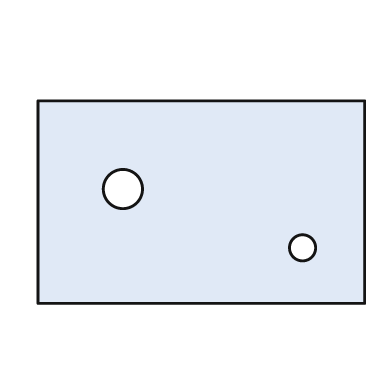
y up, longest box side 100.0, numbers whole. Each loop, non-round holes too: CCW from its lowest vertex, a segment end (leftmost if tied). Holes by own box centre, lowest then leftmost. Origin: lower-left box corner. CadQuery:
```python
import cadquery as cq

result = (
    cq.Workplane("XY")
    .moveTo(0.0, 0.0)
    .lineTo(100.0, 0.0)
    .lineTo(100.0, 62.0)
    .lineTo(0.0, 62.0)
    .close()
    .moveTo(81.0, 17.0)
    .circle(4.0)
    .moveTo(26.0, 35.0)
    .circle(6.0)
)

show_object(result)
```